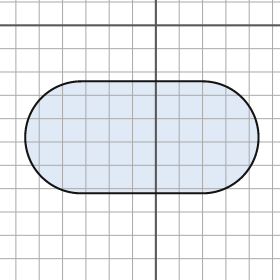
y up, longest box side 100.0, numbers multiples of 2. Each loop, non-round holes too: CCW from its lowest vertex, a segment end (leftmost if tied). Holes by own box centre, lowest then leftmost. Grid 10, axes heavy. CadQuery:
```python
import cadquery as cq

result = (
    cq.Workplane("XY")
    .moveTo(-32.0, -72.0)
    .lineTo(20.0, -72.0)
    .threePointArc((44.0, -48.0), (20.0, -24.0))
    .lineTo(-32.0, -24.0)
    .threePointArc((-56.0, -48.0), (-32.0, -72.0))
    .close()
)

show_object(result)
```